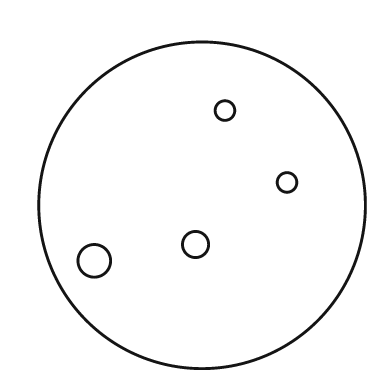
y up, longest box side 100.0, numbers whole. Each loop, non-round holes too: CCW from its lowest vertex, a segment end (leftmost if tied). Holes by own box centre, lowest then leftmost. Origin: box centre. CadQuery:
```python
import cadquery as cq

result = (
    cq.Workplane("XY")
    .moveTo(0.0, 0.0)
    .circle(50.0)
    .moveTo(-33.0, -17.0)
    .circle(5.0)
    .moveTo(-2.0, -12.0)
    .circle(4.0)
    .moveTo(26.0, 7.0)
    .circle(3.0)
    .moveTo(7.0, 29.0)
    .circle(3.0)
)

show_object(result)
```